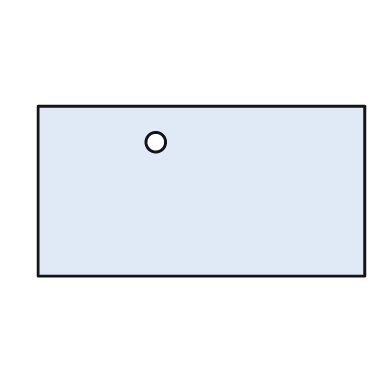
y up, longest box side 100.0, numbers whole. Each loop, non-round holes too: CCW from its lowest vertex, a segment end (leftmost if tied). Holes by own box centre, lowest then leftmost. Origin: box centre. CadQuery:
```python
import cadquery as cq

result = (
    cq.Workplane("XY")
    .moveTo(-50.0, -26.0)
    .lineTo(50.0, -26.0)
    .lineTo(50.0, 26.0)
    .lineTo(-50.0, 26.0)
    .close()
    .moveTo(-14.0, 15.0)
    .circle(3.0)
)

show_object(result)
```